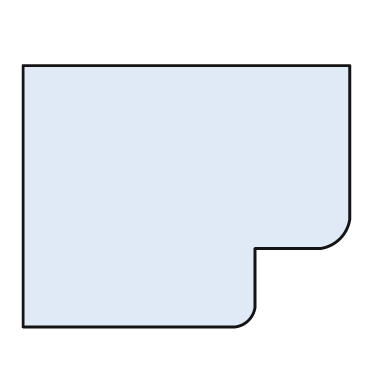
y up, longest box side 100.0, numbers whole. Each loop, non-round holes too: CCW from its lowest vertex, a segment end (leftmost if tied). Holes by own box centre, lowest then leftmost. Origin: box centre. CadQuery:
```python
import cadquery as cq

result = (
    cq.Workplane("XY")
    .moveTo(-50.0, -40.0)
    .lineTo(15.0, -40.0)
    .threePointArc((19.0, -38.0), (21.0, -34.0))
    .lineTo(21.0, -16.0)
    .lineTo(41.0, -16.0)
    .threePointArc((47.0, -13.0), (50.0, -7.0))
    .lineTo(50.0, 40.0)
    .lineTo(-50.0, 40.0)
    .close()
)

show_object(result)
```